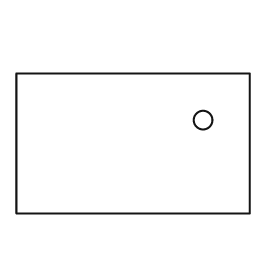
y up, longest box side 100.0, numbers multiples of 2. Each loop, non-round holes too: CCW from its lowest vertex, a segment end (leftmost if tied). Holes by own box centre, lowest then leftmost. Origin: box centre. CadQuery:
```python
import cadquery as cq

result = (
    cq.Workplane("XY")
    .moveTo(-50.0, -30.0)
    .lineTo(50.0, -30.0)
    .lineTo(50.0, 30.0)
    .lineTo(-50.0, 30.0)
    .close()
    .moveTo(30.0, 10.0)
    .circle(4.0)
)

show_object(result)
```